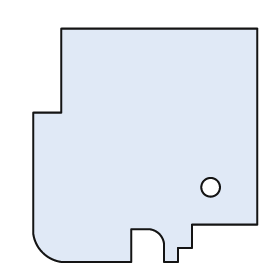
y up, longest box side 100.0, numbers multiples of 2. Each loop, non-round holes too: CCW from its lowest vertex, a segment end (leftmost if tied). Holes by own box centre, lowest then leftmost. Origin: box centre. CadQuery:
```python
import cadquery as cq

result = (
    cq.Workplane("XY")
    .moveTo(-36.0, -50.0)
    .lineTo(-6.0, -50.0)
    .lineTo(-6.0, -36.0)
    .lineTo(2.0, -36.0)
    .threePointArc((6.0, -38.0), (8.0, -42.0))
    .lineTo(8.0, -50.0)
    .lineTo(14.0, -50.0)
    .lineTo(14.0, -44.0)
    .lineTo(20.0, -44.0)
    .lineTo(20.0, -34.0)
    .lineTo(48.0, -34.0)
    .lineTo(48.0, 50.0)
    .lineTo(-36.0, 50.0)
    .lineTo(-36.0, 14.0)
    .lineTo(-48.0, 14.0)
    .lineTo(-48.0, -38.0)
    .threePointArc((-44.0, -46.0), (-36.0, -50.0))
    .close()
    .moveTo(28.0, -18.0)
    .circle(4.0)
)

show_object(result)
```